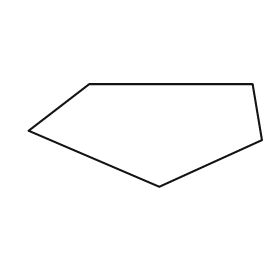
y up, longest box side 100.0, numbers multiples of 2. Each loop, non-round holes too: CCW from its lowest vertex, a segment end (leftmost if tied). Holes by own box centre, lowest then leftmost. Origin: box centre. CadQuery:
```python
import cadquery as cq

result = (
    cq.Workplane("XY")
    .moveTo(6.0, -22.0)
    .lineTo(50.0, -2.0)
    .lineTo(46.0, 22.0)
    .lineTo(-24.0, 22.0)
    .lineTo(-50.0, 2.0)
    .close()
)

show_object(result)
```